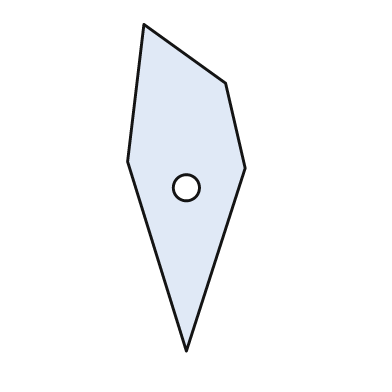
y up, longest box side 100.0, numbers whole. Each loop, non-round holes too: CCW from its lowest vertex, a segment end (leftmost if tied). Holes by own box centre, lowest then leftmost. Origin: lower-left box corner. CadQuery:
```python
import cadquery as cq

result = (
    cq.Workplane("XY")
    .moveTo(18.0, 0.0)
    .lineTo(36.0, 56.0)
    .lineTo(30.0, 82.0)
    .lineTo(5.0, 100.0)
    .lineTo(0.0, 58.0)
    .close()
    .moveTo(18.0, 50.0)
    .circle(4.0)
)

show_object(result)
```